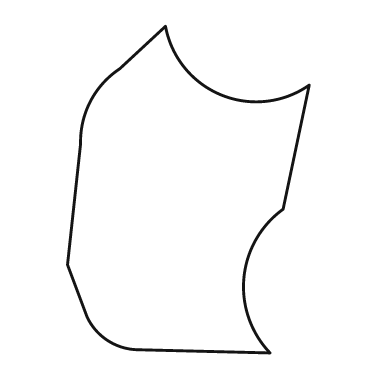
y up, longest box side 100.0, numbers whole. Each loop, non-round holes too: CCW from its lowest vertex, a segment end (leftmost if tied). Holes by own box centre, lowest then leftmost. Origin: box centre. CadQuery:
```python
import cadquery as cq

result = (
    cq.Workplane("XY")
    .moveTo(25.0, -50.0)
    .threePointArc((17.0, -27.0), (29.0, -6.0))
    .lineTo(37.0, 32.0)
    .threePointArc((10.0, 29.0), (-7.0, 50.0))
    .lineTo(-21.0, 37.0)
    .threePointArc((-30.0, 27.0), (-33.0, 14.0))
    .lineTo(-37.0, -23.0)
    .lineTo(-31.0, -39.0)
    .threePointArc((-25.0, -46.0), (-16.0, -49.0))
    .close()
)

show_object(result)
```